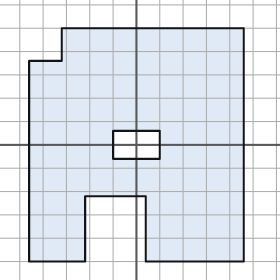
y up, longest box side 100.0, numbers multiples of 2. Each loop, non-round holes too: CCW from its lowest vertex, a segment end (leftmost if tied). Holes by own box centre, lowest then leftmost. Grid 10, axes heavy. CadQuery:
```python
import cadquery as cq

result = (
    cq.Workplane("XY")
    .moveTo(-46.0, -50.0)
    .lineTo(-22.0, -50.0)
    .lineTo(-22.0, -22.0)
    .lineTo(4.0, -22.0)
    .lineTo(4.0, -50.0)
    .lineTo(46.0, -50.0)
    .lineTo(46.0, 50.0)
    .lineTo(-32.0, 50.0)
    .lineTo(-32.0, 36.0)
    .lineTo(-46.0, 36.0)
    .close()
    .moveTo(-10.0, -6.0)
    .lineTo(10.0, -6.0)
    .lineTo(10.0, 6.0)
    .lineTo(-10.0, 6.0)
    .close()
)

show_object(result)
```